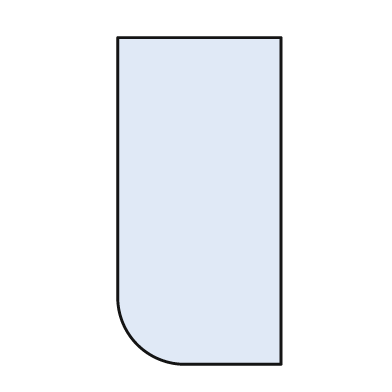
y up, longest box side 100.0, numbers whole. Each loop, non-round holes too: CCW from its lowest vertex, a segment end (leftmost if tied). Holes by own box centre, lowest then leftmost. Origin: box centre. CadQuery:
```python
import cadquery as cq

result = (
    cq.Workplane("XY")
    .moveTo(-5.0, -50.0)
    .lineTo(25.0, -50.0)
    .lineTo(25.0, 50.0)
    .lineTo(-25.0, 50.0)
    .lineTo(-25.0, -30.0)
    .threePointArc((-19.0, -44.0), (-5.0, -50.0))
    .close()
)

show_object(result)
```